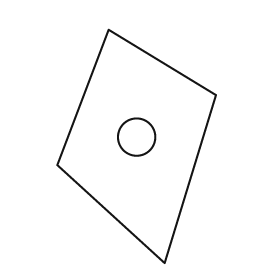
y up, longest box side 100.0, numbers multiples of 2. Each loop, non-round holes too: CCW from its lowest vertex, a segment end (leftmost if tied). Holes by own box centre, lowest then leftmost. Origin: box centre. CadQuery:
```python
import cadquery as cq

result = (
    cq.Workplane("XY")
    .moveTo(12.0, -50.0)
    .lineTo(34.0, 22.0)
    .lineTo(-12.0, 50.0)
    .lineTo(-34.0, -8.0)
    .close()
    .moveTo(0.0, 4.0)
    .circle(8.0)
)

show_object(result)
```